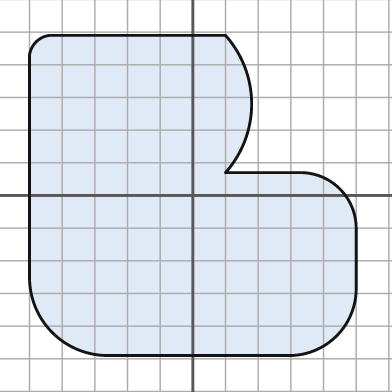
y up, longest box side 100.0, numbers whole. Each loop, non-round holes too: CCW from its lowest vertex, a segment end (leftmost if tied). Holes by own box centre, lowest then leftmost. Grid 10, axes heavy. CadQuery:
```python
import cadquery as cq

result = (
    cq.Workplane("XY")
    .moveTo(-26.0, -49.0)
    .lineTo(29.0, -49.0)
    .threePointArc((44.0, -43.0), (50.0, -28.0))
    .lineTo(50.0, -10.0)
    .threePointArc((45.0, 2.0), (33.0, 7.0))
    .lineTo(10.0, 7.0)
    .threePointArc((18.0, 28.0), (10.0, 49.0))
    .lineTo(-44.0, 49.0)
    .threePointArc((-48.0, 47.0), (-50.0, 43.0))
    .lineTo(-50.0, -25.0)
    .threePointArc((-43.0, -42.0), (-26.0, -49.0))
    .close()
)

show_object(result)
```